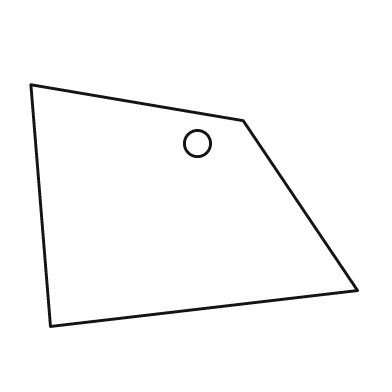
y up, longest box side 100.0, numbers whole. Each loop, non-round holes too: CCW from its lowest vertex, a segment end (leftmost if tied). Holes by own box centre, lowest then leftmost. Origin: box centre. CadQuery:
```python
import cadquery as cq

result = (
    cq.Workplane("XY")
    .moveTo(-44.0, -37.0)
    .lineTo(50.0, -26.0)
    .lineTo(15.0, 26.0)
    .lineTo(-50.0, 37.0)
    .close()
    .moveTo(1.0, 19.0)
    .circle(4.0)
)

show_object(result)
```